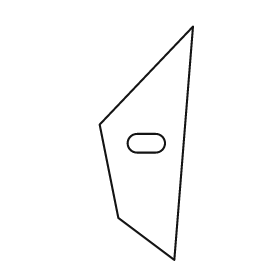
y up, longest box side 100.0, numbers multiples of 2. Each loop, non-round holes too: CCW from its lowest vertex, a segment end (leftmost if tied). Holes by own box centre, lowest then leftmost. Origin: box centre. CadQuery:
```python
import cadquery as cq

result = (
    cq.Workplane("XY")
    .moveTo(12.0, -50.0)
    .lineTo(20.0, 50.0)
    .lineTo(-20.0, 8.0)
    .lineTo(-12.0, -32.0)
    .close()
    .moveTo(-4.0, -4.0)
    .lineTo(4.0, -4.0)
    .threePointArc((8.0, 0.0), (4.0, 4.0))
    .lineTo(-4.0, 4.0)
    .threePointArc((-8.0, 0.0), (-4.0, -4.0))
    .close()
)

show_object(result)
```